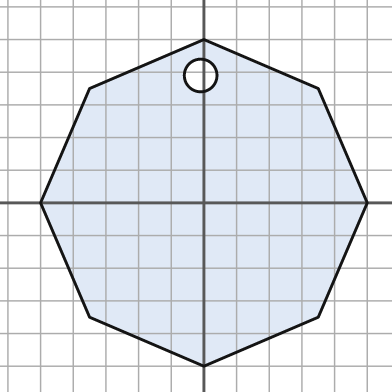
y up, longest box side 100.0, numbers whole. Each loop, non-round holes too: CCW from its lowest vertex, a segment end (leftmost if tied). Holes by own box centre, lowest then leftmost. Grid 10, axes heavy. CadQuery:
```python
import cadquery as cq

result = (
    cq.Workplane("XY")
    .moveTo(0.0, -50.0)
    .lineTo(35.0, -35.0)
    .lineTo(50.0, 0.0)
    .lineTo(35.0, 35.0)
    .lineTo(0.0, 50.0)
    .lineTo(-35.0, 35.0)
    .lineTo(-50.0, 0.0)
    .lineTo(-35.0, -35.0)
    .close()
    .moveTo(-1.0, 39.0)
    .circle(5.0)
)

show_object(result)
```